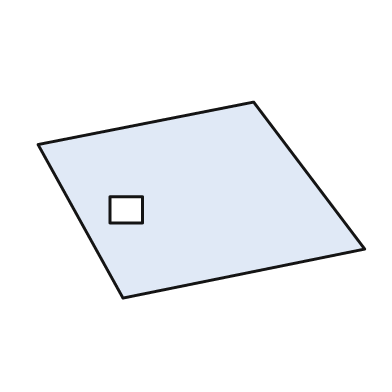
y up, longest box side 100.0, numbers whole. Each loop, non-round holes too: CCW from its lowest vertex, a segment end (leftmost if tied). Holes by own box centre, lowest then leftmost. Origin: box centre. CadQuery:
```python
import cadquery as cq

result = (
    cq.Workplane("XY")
    .moveTo(-24.0, -30.0)
    .lineTo(50.0, -15.0)
    .lineTo(16.0, 30.0)
    .lineTo(-50.0, 17.0)
    .close()
    .moveTo(-28.0, -7.0)
    .lineTo(-18.0, -7.0)
    .lineTo(-18.0, 1.0)
    .lineTo(-28.0, 1.0)
    .close()
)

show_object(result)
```